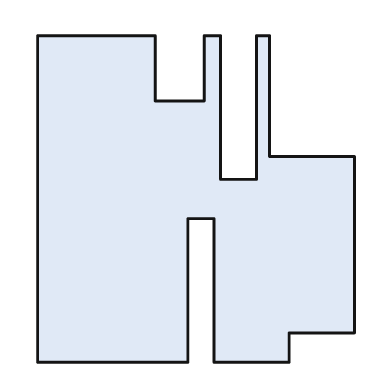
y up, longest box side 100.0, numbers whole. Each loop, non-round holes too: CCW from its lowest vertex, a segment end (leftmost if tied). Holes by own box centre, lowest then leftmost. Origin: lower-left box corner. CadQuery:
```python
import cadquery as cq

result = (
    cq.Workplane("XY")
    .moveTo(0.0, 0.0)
    .lineTo(46.0, 0.0)
    .lineTo(46.0, 44.0)
    .lineTo(54.0, 44.0)
    .lineTo(54.0, 0.0)
    .lineTo(77.0, 0.0)
    .lineTo(77.0, 9.0)
    .lineTo(97.0, 9.0)
    .lineTo(97.0, 63.0)
    .lineTo(71.0, 63.0)
    .lineTo(71.0, 100.0)
    .lineTo(67.0, 100.0)
    .lineTo(67.0, 56.0)
    .lineTo(56.0, 56.0)
    .lineTo(56.0, 100.0)
    .lineTo(51.0, 100.0)
    .lineTo(51.0, 80.0)
    .lineTo(36.0, 80.0)
    .lineTo(36.0, 100.0)
    .lineTo(0.0, 100.0)
    .close()
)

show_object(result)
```